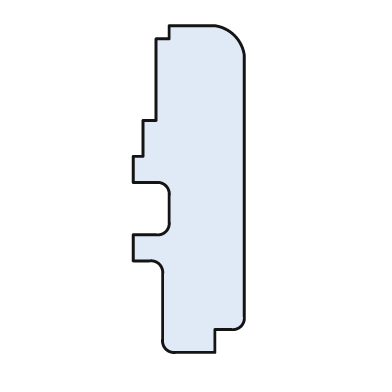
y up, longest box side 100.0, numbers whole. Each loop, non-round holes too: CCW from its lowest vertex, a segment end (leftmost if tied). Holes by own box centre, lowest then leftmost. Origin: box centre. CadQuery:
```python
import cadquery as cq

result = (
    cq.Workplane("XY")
    .moveTo(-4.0, -50.0)
    .lineTo(8.0, -50.0)
    .lineTo(8.0, -43.0)
    .lineTo(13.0, -43.0)
    .threePointArc((16.0, -42.0), (17.0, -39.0))
    .lineTo(17.0, 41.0)
    .threePointArc((14.0, 47.0), (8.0, 50.0))
    .lineTo(-6.0, 50.0)
    .lineTo(-6.0, 46.0)
    .lineTo(-10.0, 46.0)
    .lineTo(-10.0, 21.0)
    .lineTo(-14.0, 21.0)
    .lineTo(-14.0, 10.0)
    .lineTo(-17.0, 10.0)
    .lineTo(-17.0, 2.0)
    .lineTo(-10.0, 2.0)
    .threePointArc((-7.0, 1.0), (-6.0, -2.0))
    .lineTo(-6.0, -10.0)
    .threePointArc((-7.0, -13.0), (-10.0, -14.0))
    .lineTo(-17.0, -14.0)
    .lineTo(-17.0, -22.0)
    .lineTo(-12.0, -22.0)
    .threePointArc((-9.0, -23.0), (-8.0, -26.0))
    .lineTo(-8.0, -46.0)
    .threePointArc((-7.0, -49.0), (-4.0, -50.0))
    .close()
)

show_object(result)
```